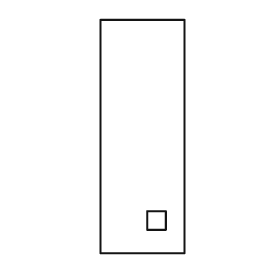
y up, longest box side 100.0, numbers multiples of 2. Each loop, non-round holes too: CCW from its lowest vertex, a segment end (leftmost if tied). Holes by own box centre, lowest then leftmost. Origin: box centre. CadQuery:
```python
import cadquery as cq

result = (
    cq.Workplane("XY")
    .moveTo(-18.0, -50.0)
    .lineTo(18.0, -50.0)
    .lineTo(18.0, 50.0)
    .lineTo(-18.0, 50.0)
    .close()
    .moveTo(2.0, -40.0)
    .lineTo(10.0, -40.0)
    .lineTo(10.0, -32.0)
    .lineTo(2.0, -32.0)
    .close()
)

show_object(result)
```